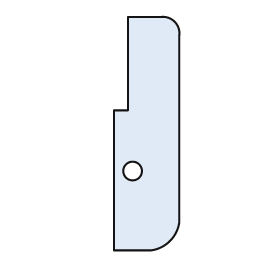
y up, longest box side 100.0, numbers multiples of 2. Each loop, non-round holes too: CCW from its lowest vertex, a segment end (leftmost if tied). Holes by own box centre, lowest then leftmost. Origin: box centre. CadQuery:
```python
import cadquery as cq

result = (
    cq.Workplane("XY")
    .moveTo(-14.0, -50.0)
    .lineTo(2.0, -50.0)
    .threePointArc((10.0, -46.0), (14.0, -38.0))
    .lineTo(14.0, 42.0)
    .threePointArc((12.0, 48.0), (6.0, 50.0))
    .lineTo(-8.0, 50.0)
    .lineTo(-8.0, 10.0)
    .lineTo(-14.0, 10.0)
    .close()
    .moveTo(-6.0, -16.0)
    .circle(4.0)
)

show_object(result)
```